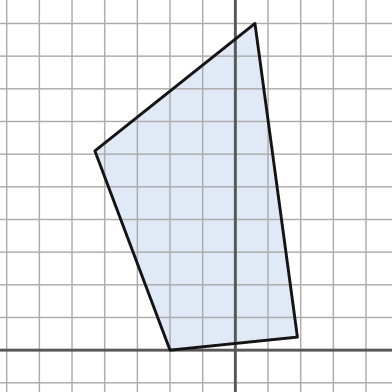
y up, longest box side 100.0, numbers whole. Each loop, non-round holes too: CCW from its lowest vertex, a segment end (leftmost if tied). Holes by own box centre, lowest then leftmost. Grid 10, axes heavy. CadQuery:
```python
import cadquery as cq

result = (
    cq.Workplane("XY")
    .moveTo(-20.0, 0.0)
    .lineTo(19.0, 4.0)
    .lineTo(6.0, 100.0)
    .lineTo(-43.0, 61.0)
    .close()
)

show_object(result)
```